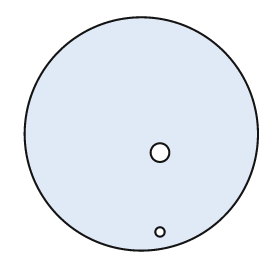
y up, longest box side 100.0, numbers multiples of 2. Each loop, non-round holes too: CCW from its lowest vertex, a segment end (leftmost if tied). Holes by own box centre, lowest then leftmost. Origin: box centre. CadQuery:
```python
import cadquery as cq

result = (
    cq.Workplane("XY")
    .moveTo(0.0, 0.0)
    .circle(50.0)
    .moveTo(8.0, -42.0)
    .circle(2.0)
    .moveTo(8.0, -8.0)
    .circle(4.0)
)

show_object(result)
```